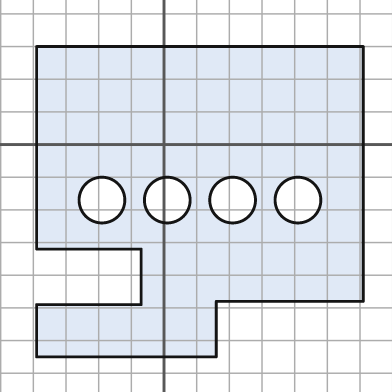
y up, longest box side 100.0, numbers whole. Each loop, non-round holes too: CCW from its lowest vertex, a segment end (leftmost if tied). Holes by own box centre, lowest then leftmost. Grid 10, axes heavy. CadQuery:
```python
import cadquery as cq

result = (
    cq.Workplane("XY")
    .moveTo(-39.0, -65.0)
    .lineTo(16.0, -65.0)
    .lineTo(16.0, -48.0)
    .lineTo(61.0, -48.0)
    .lineTo(61.0, 30.0)
    .lineTo(-39.0, 30.0)
    .lineTo(-39.0, -32.0)
    .lineTo(-7.0, -32.0)
    .lineTo(-7.0, -49.0)
    .lineTo(-39.0, -49.0)
    .close()
    .moveTo(-19.0, -17.0)
    .circle(7.0)
    .moveTo(1.0, -17.0)
    .circle(7.0)
    .moveTo(21.0, -17.0)
    .circle(7.0)
    .moveTo(41.0, -17.0)
    .circle(7.0)
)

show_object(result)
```